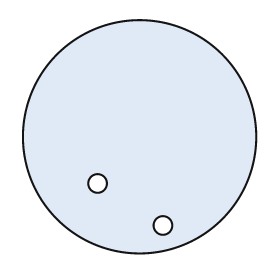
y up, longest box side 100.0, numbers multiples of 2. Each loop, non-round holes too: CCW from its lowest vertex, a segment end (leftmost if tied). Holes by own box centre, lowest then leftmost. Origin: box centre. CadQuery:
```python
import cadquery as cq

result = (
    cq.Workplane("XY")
    .moveTo(0.0, 0.0)
    .circle(50.0)
    .moveTo(10.0, -38.0)
    .circle(4.0)
    .moveTo(-18.0, -20.0)
    .circle(4.0)
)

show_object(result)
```